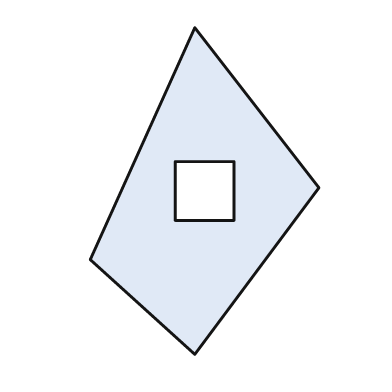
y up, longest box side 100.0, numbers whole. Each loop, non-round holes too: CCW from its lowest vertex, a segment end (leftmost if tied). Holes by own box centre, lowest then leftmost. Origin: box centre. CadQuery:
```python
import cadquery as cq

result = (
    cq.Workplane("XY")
    .moveTo(-3.0, -50.0)
    .lineTo(35.0, 1.0)
    .lineTo(-3.0, 50.0)
    .lineTo(-35.0, -21.0)
    .close()
    .moveTo(-9.0, -9.0)
    .lineTo(9.0, -9.0)
    .lineTo(9.0, 9.0)
    .lineTo(-9.0, 9.0)
    .close()
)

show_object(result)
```